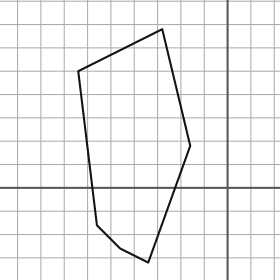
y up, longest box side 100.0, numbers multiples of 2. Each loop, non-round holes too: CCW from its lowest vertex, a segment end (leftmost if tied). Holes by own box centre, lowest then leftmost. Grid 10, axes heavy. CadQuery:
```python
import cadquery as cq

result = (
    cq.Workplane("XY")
    .moveTo(-34.0, -32.0)
    .lineTo(-16.0, 18.0)
    .lineTo(-28.0, 68.0)
    .lineTo(-64.0, 50.0)
    .lineTo(-56.0, -16.0)
    .lineTo(-46.0, -26.0)
    .close()
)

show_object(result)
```